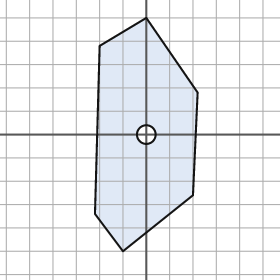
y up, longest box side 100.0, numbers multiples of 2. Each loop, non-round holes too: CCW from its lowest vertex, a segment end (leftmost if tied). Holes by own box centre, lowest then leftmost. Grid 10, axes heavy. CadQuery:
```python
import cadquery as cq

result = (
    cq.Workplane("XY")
    .moveTo(-10.0, -50.0)
    .lineTo(20.0, -26.0)
    .lineTo(22.0, 18.0)
    .lineTo(0.0, 50.0)
    .lineTo(-20.0, 38.0)
    .lineTo(-22.0, -34.0)
    .close()
    .moveTo(0.0, 0.0)
    .circle(4.0)
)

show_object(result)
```